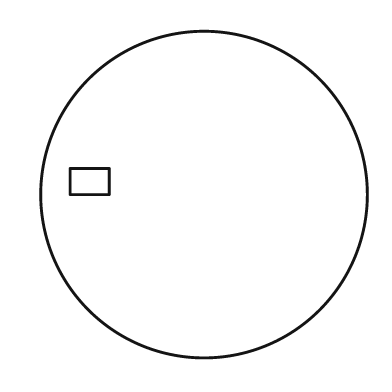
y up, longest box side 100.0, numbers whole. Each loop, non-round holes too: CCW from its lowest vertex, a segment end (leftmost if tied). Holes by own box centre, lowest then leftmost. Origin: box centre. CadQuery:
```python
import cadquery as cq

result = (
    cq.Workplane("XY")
    .moveTo(0.0, 0.0)
    .circle(50.0)
    .moveTo(-41.0, 0.0)
    .lineTo(-29.0, 0.0)
    .lineTo(-29.0, 8.0)
    .lineTo(-41.0, 8.0)
    .close()
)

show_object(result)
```